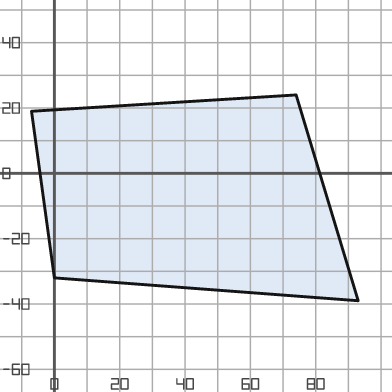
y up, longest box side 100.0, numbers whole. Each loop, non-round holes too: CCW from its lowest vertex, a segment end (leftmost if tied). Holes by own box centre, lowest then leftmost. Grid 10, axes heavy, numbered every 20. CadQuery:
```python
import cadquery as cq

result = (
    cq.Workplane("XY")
    .moveTo(93.0, -39.0)
    .lineTo(74.0, 24.0)
    .lineTo(-7.0, 19.0)
    .lineTo(0.0, -32.0)
    .close()
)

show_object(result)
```